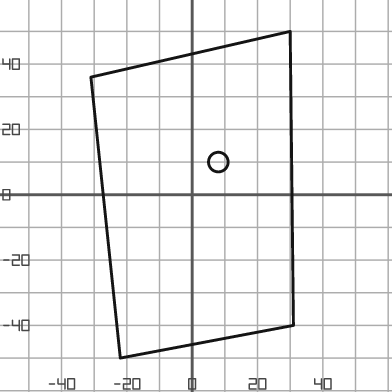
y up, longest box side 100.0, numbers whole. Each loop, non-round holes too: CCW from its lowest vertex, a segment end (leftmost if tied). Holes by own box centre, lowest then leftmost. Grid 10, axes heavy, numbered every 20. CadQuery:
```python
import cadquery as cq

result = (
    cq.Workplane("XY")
    .moveTo(-22.0, -50.0)
    .lineTo(31.0, -40.0)
    .lineTo(30.0, 50.0)
    .lineTo(-31.0, 36.0)
    .close()
    .moveTo(8.0, 10.0)
    .circle(3.0)
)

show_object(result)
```